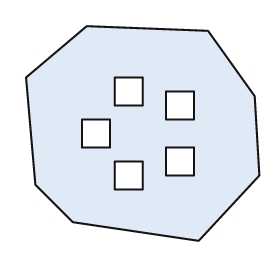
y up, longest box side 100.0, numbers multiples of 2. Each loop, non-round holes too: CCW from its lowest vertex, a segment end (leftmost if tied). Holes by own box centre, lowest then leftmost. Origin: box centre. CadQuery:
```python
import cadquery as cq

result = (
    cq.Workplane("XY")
    .moveTo(24.0, -46.0)
    .lineTo(50.0, -18.0)
    .lineTo(48.0, 16.0)
    .lineTo(28.0, 44.0)
    .lineTo(-24.0, 46.0)
    .lineTo(-50.0, 24.0)
    .lineTo(-46.0, -22.0)
    .lineTo(-30.0, -38.0)
    .close()
    .moveTo(-12.0, -24.0)
    .lineTo(0.0, -24.0)
    .lineTo(0.0, -12.0)
    .lineTo(-12.0, -12.0)
    .close()
    .moveTo(10.0, -18.0)
    .lineTo(22.0, -18.0)
    .lineTo(22.0, -6.0)
    .lineTo(10.0, -6.0)
    .close()
    .moveTo(-26.0, -6.0)
    .lineTo(-14.0, -6.0)
    .lineTo(-14.0, 6.0)
    .lineTo(-26.0, 6.0)
    .close()
    .moveTo(10.0, 6.0)
    .lineTo(22.0, 6.0)
    .lineTo(22.0, 18.0)
    .lineTo(10.0, 18.0)
    .close()
    .moveTo(-12.0, 12.0)
    .lineTo(0.0, 12.0)
    .lineTo(0.0, 24.0)
    .lineTo(-12.0, 24.0)
    .close()
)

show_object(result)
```